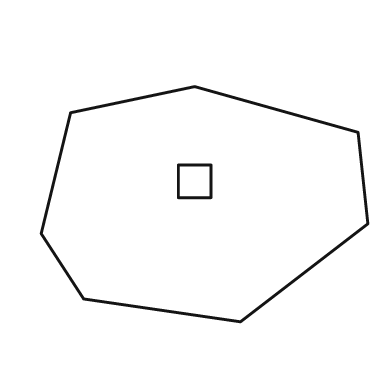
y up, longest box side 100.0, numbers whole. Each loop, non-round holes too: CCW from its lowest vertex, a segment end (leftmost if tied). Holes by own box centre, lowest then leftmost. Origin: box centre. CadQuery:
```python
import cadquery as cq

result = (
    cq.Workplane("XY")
    .moveTo(11.0, -36.0)
    .lineTo(50.0, -6.0)
    .lineTo(47.0, 22.0)
    .lineTo(-3.0, 36.0)
    .lineTo(-41.0, 28.0)
    .lineTo(-50.0, -9.0)
    .lineTo(-37.0, -29.0)
    .close()
    .moveTo(-8.0, 2.0)
    .lineTo(2.0, 2.0)
    .lineTo(2.0, 12.0)
    .lineTo(-8.0, 12.0)
    .close()
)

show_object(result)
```